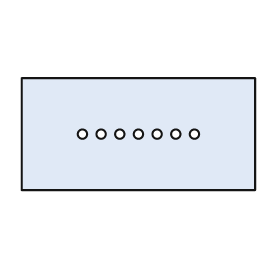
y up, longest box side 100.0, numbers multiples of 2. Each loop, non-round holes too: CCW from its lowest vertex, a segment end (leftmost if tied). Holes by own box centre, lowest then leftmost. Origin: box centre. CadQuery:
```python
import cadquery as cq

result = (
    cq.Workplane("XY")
    .moveTo(-50.0, -24.0)
    .lineTo(50.0, -24.0)
    .lineTo(50.0, 24.0)
    .lineTo(-50.0, 24.0)
    .close()
    .moveTo(-24.0, 0.0)
    .circle(2.0)
    .moveTo(-16.0, 0.0)
    .circle(2.0)
    .moveTo(-8.0, 0.0)
    .circle(2.0)
    .moveTo(0.0, 0.0)
    .circle(2.0)
    .moveTo(8.0, 0.0)
    .circle(2.0)
    .moveTo(16.0, 0.0)
    .circle(2.0)
    .moveTo(24.0, 0.0)
    .circle(2.0)
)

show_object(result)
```